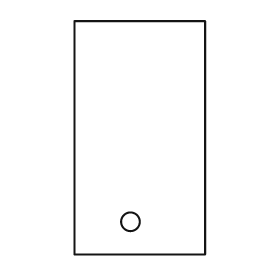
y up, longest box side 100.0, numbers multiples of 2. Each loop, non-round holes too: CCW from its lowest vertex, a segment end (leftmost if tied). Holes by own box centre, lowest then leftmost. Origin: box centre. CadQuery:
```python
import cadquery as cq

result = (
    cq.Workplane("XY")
    .moveTo(-28.0, -50.0)
    .lineTo(28.0, -50.0)
    .lineTo(28.0, 50.0)
    .lineTo(-28.0, 50.0)
    .close()
    .moveTo(-4.0, -36.0)
    .circle(4.0)
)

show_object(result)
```